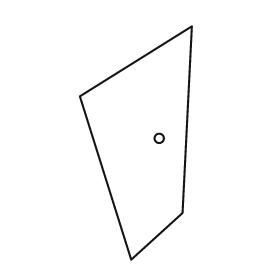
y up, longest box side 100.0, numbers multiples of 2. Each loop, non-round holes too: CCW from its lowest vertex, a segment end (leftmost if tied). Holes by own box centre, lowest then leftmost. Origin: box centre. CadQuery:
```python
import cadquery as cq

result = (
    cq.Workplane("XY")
    .moveTo(-2.0, -50.0)
    .lineTo(20.0, -30.0)
    .lineTo(24.0, 50.0)
    .lineTo(-24.0, 20.0)
    .close()
    .moveTo(10.0, 2.0)
    .circle(2.0)
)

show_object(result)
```